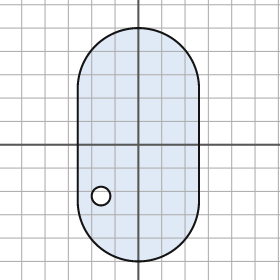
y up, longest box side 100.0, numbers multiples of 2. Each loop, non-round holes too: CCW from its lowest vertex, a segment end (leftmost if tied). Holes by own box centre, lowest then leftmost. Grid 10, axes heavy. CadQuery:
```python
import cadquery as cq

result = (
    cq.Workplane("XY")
    .moveTo(-26.0, -24.0)
    .threePointArc((0.0, -50.0), (26.0, -24.0))
    .lineTo(26.0, 24.0)
    .threePointArc((0.0, 50.0), (-26.0, 24.0))
    .close()
    .moveTo(-16.0, -22.0)
    .circle(4.0)
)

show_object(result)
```